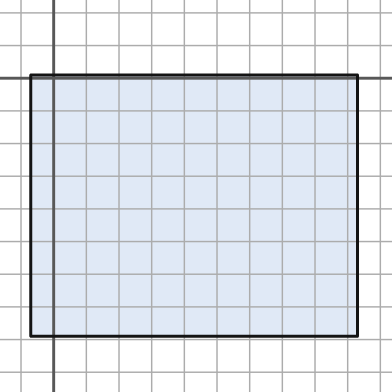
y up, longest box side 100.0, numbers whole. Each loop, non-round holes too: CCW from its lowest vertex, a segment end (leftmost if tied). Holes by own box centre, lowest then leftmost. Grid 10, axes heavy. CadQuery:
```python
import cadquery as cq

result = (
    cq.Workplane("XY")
    .moveTo(-7.0, -79.0)
    .lineTo(93.0, -79.0)
    .lineTo(93.0, 1.0)
    .lineTo(-7.0, 1.0)
    .close()
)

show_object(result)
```